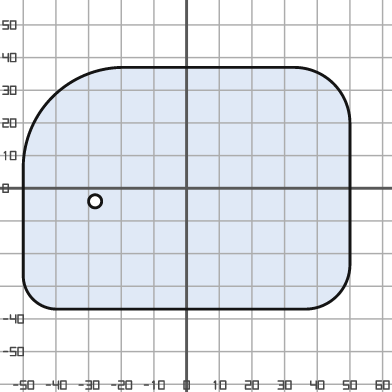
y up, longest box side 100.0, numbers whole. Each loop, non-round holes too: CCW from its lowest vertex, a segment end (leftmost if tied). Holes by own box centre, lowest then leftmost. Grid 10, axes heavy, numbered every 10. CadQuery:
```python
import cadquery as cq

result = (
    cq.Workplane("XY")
    .moveTo(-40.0, -37.0)
    .lineTo(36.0, -37.0)
    .threePointArc((46.0, -33.0), (50.0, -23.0))
    .lineTo(50.0, 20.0)
    .threePointArc((45.0, 32.0), (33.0, 37.0))
    .lineTo(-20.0, 37.0)
    .threePointArc((-41.0, 28.0), (-50.0, 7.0))
    .lineTo(-50.0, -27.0)
    .threePointArc((-47.0, -34.0), (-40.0, -37.0))
    .close()
    .moveTo(-28.0, -4.0)
    .circle(2.0)
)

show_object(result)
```